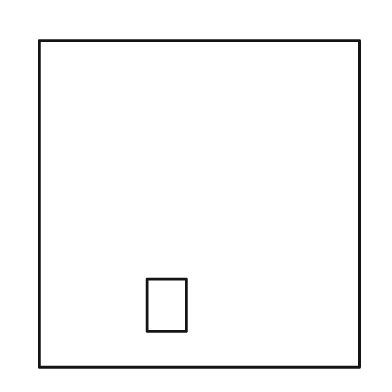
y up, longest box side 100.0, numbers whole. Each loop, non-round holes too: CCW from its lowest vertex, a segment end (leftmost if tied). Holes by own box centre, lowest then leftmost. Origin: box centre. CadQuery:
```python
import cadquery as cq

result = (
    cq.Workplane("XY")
    .moveTo(-49.0, -50.0)
    .lineTo(49.0, -50.0)
    .lineTo(49.0, 50.0)
    .lineTo(-49.0, 50.0)
    .close()
    .moveTo(-16.0, -39.0)
    .lineTo(-4.0, -39.0)
    .lineTo(-4.0, -23.0)
    .lineTo(-16.0, -23.0)
    .close()
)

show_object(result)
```